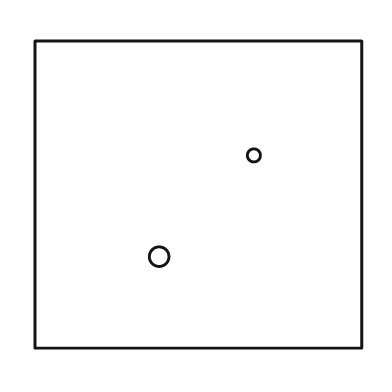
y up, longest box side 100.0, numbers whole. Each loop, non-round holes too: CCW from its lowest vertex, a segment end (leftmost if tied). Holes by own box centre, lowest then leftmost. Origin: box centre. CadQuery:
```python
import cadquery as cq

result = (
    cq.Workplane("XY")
    .moveTo(-50.0, -47.0)
    .lineTo(50.0, -47.0)
    .lineTo(50.0, 47.0)
    .lineTo(-50.0, 47.0)
    .close()
    .moveTo(-12.0, -19.0)
    .circle(3.0)
    .moveTo(17.0, 12.0)
    .circle(2.0)
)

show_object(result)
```